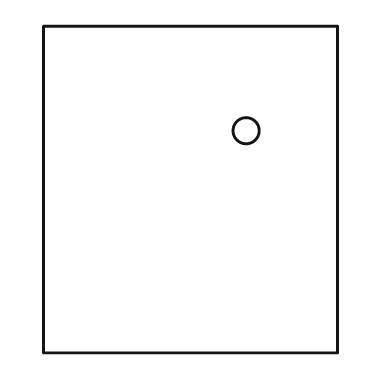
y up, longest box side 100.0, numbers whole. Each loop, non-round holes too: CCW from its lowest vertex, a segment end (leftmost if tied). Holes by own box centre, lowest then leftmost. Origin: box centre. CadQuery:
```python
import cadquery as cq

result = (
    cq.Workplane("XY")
    .moveTo(-45.0, -50.0)
    .lineTo(45.0, -50.0)
    .lineTo(45.0, 50.0)
    .lineTo(-45.0, 50.0)
    .close()
    .moveTo(17.0, 18.0)
    .circle(4.0)
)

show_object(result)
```